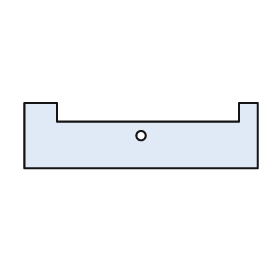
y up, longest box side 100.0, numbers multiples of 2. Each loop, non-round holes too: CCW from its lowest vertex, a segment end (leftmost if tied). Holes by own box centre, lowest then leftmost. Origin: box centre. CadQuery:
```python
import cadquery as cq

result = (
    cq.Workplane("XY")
    .moveTo(-50.0, -14.0)
    .lineTo(50.0, -14.0)
    .lineTo(50.0, 14.0)
    .lineTo(42.0, 14.0)
    .lineTo(42.0, 6.0)
    .lineTo(-36.0, 6.0)
    .lineTo(-36.0, 14.0)
    .lineTo(-50.0, 14.0)
    .close()
    .moveTo(0.0, 0.0)
    .circle(2.0)
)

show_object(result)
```